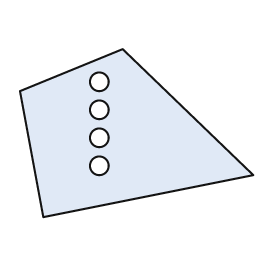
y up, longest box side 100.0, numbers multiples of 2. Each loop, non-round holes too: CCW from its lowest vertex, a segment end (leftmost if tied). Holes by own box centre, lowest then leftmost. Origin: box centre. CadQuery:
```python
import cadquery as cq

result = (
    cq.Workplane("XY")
    .moveTo(-40.0, -36.0)
    .lineTo(50.0, -18.0)
    .lineTo(-6.0, 36.0)
    .lineTo(-50.0, 18.0)
    .close()
    .moveTo(-16.0, -14.0)
    .circle(4.0)
    .moveTo(-16.0, -2.0)
    .circle(4.0)
    .moveTo(-16.0, 10.0)
    .circle(4.0)
    .moveTo(-16.0, 22.0)
    .circle(4.0)
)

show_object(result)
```